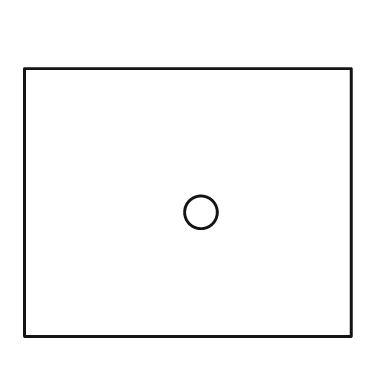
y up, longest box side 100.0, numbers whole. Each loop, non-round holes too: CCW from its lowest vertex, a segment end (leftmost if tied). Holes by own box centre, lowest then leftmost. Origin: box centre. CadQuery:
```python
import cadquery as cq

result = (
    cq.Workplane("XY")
    .moveTo(-50.0, -41.0)
    .lineTo(50.0, -41.0)
    .lineTo(50.0, 41.0)
    .lineTo(-50.0, 41.0)
    .close()
    .moveTo(4.0, -3.0)
    .circle(5.0)
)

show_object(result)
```